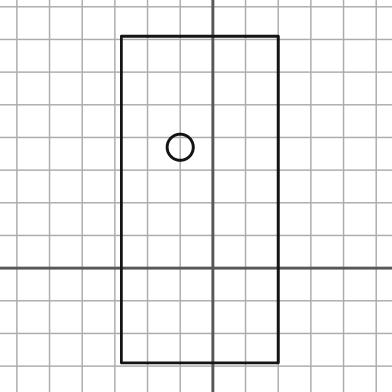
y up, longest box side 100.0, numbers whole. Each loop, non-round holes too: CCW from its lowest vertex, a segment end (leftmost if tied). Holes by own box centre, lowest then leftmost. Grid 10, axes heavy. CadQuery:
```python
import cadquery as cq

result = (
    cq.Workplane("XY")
    .moveTo(-28.0, -29.0)
    .lineTo(20.0, -29.0)
    .lineTo(20.0, 71.0)
    .lineTo(-28.0, 71.0)
    .close()
    .moveTo(-10.0, 37.0)
    .circle(4.0)
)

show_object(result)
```